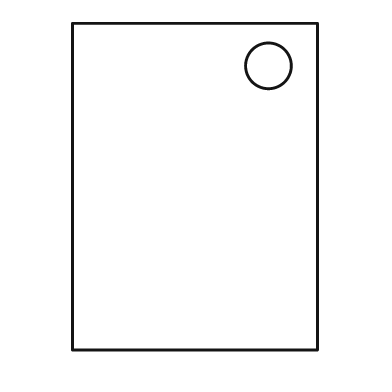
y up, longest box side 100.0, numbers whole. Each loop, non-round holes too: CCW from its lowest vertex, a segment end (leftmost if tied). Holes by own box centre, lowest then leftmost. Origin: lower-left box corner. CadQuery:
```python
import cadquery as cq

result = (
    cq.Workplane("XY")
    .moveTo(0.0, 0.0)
    .lineTo(75.0, 0.0)
    .lineTo(75.0, 100.0)
    .lineTo(0.0, 100.0)
    .close()
    .moveTo(60.0, 87.0)
    .circle(7.0)
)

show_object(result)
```